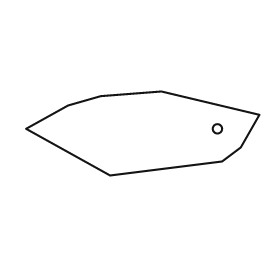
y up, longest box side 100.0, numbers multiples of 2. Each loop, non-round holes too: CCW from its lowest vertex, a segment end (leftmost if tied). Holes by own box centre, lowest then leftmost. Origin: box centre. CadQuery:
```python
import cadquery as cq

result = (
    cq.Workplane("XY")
    .moveTo(-14.0, -18.0)
    .lineTo(34.0, -12.0)
    .lineTo(42.0, -6.0)
    .lineTo(50.0, 8.0)
    .lineTo(8.0, 18.0)
    .lineTo(-18.0, 16.0)
    .lineTo(-32.0, 12.0)
    .lineTo(-50.0, 2.0)
    .close()
    .moveTo(32.0, 2.0)
    .circle(2.0)
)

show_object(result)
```